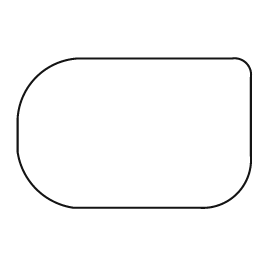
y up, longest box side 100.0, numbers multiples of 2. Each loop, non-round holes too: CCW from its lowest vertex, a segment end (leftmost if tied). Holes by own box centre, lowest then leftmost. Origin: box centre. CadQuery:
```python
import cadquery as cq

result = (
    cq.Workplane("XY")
    .moveTo(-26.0, -32.0)
    .lineTo(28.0, -32.0)
    .threePointArc((44.0, -26.0), (50.0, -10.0))
    .lineTo(50.0, 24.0)
    .threePointArc((48.0, 30.0), (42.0, 32.0))
    .lineTo(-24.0, 32.0)
    .threePointArc((-42.0, 24.0), (-50.0, 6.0))
    .lineTo(-50.0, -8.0)
    .threePointArc((-42.0, -24.0), (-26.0, -32.0))
    .close()
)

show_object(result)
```